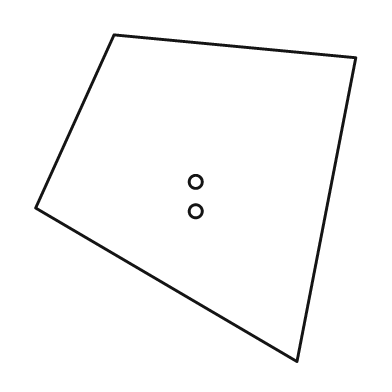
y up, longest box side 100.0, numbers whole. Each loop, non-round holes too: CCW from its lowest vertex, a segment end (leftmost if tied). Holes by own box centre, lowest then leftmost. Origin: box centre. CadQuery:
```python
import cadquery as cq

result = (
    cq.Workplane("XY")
    .moveTo(31.0, -50.0)
    .lineTo(49.0, 43.0)
    .lineTo(-25.0, 50.0)
    .lineTo(-49.0, -3.0)
    .close()
    .moveTo(0.0, -4.0)
    .circle(2.0)
    .moveTo(0.0, 5.0)
    .circle(2.0)
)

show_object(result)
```